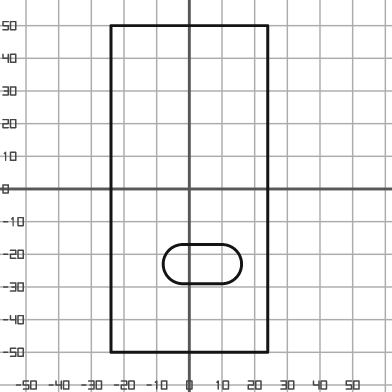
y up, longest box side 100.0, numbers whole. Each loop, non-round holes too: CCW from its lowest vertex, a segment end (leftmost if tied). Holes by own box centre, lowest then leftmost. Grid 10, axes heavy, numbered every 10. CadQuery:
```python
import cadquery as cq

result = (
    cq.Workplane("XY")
    .moveTo(-24.0, -50.0)
    .lineTo(24.0, -50.0)
    .lineTo(24.0, 50.0)
    .lineTo(-24.0, 50.0)
    .close()
    .moveTo(-2.0, -29.0)
    .lineTo(10.0, -29.0)
    .threePointArc((16.0, -23.0), (10.0, -17.0))
    .lineTo(-2.0, -17.0)
    .threePointArc((-8.0, -23.0), (-2.0, -29.0))
    .close()
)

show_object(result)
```